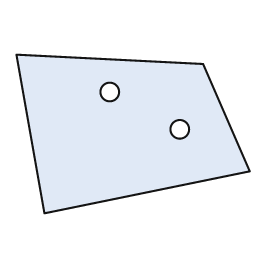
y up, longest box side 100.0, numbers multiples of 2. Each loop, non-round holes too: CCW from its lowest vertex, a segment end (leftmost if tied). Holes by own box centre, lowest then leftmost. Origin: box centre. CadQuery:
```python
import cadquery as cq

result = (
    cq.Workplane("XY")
    .moveTo(-38.0, -34.0)
    .lineTo(50.0, -16.0)
    .lineTo(30.0, 30.0)
    .lineTo(-50.0, 34.0)
    .close()
    .moveTo(20.0, 2.0)
    .circle(4.0)
    .moveTo(-10.0, 18.0)
    .circle(4.0)
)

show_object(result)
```